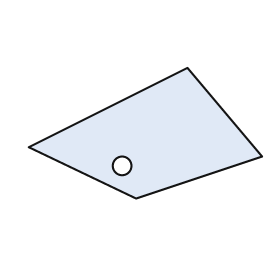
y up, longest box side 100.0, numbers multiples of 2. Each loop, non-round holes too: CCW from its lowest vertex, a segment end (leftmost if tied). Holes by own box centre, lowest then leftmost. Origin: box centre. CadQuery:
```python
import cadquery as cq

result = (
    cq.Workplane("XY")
    .moveTo(-4.0, -28.0)
    .lineTo(50.0, -10.0)
    .lineTo(18.0, 28.0)
    .lineTo(-50.0, -6.0)
    .close()
    .moveTo(-10.0, -14.0)
    .circle(4.0)
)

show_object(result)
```